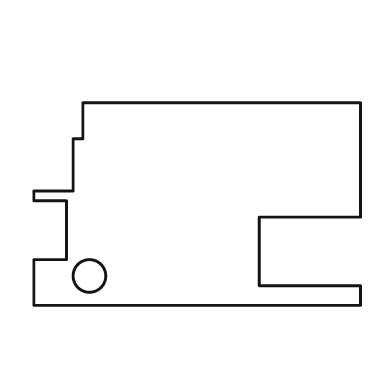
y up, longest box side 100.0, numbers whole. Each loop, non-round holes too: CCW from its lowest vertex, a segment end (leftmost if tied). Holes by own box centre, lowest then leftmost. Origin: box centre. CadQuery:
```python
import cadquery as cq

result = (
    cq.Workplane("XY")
    .moveTo(-50.0, -31.0)
    .lineTo(50.0, -31.0)
    .lineTo(50.0, -25.0)
    .lineTo(19.0, -25.0)
    .lineTo(19.0, -4.0)
    .lineTo(50.0, -4.0)
    .lineTo(50.0, 31.0)
    .lineTo(-35.0, 31.0)
    .lineTo(-35.0, 20.0)
    .lineTo(-38.0, 20.0)
    .lineTo(-38.0, 4.0)
    .lineTo(-50.0, 4.0)
    .lineTo(-50.0, 1.0)
    .lineTo(-40.0, 1.0)
    .lineTo(-40.0, -17.0)
    .lineTo(-50.0, -17.0)
    .close()
    .moveTo(-33.0, -22.0)
    .circle(5.0)
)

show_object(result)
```